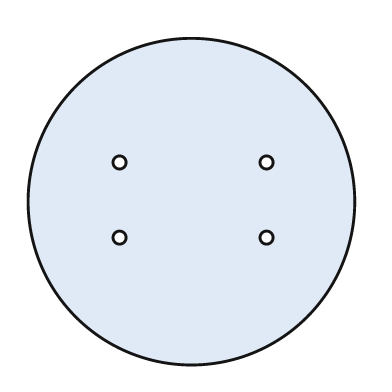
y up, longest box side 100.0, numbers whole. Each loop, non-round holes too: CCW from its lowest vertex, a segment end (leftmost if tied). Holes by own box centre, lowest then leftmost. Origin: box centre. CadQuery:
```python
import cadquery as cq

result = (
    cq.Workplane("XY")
    .moveTo(0.0, 0.0)
    .circle(50.0)
    .moveTo(-22.0, -11.0)
    .circle(2.0)
    .moveTo(23.0, -11.0)
    .circle(2.0)
    .moveTo(-22.0, 12.0)
    .circle(2.0)
    .moveTo(23.0, 12.0)
    .circle(2.0)
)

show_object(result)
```